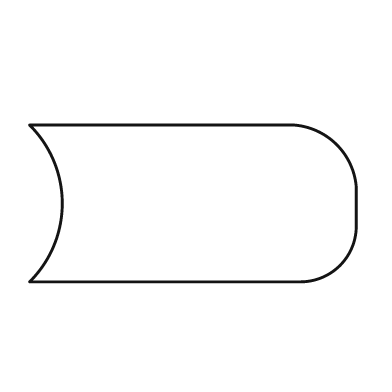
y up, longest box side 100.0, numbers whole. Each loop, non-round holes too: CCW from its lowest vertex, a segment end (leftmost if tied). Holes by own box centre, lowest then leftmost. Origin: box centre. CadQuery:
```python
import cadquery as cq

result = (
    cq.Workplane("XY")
    .moveTo(-50.0, -24.0)
    .lineTo(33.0, -24.0)
    .threePointArc((45.0, -19.0), (50.0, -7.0))
    .lineTo(50.0, 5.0)
    .threePointArc((44.0, 18.0), (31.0, 24.0))
    .lineTo(-50.0, 24.0)
    .threePointArc((-40.0, 0.0), (-50.0, -24.0))
    .close()
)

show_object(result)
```